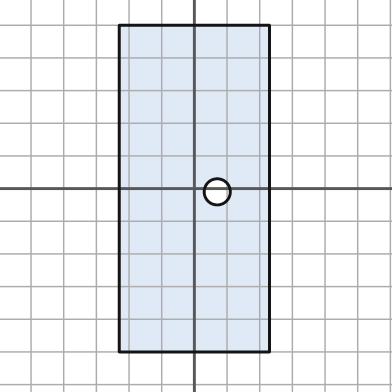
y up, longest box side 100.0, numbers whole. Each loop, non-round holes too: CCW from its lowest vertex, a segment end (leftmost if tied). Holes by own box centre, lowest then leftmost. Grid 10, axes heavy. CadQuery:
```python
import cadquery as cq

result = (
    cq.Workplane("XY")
    .moveTo(-23.0, -50.0)
    .lineTo(23.0, -50.0)
    .lineTo(23.0, 50.0)
    .lineTo(-23.0, 50.0)
    .close()
    .moveTo(7.0, -1.0)
    .circle(4.0)
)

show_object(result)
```